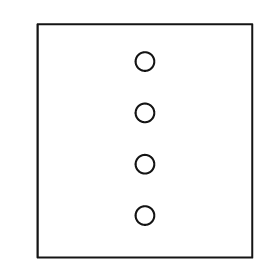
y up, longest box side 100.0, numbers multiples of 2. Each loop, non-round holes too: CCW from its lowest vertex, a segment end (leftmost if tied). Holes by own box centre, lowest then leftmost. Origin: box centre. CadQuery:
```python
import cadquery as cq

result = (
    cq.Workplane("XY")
    .moveTo(-46.0, -50.0)
    .lineTo(46.0, -50.0)
    .lineTo(46.0, 50.0)
    .lineTo(-46.0, 50.0)
    .close()
    .moveTo(0.0, -32.0)
    .circle(4.0)
    .moveTo(0.0, -10.0)
    .circle(4.0)
    .moveTo(0.0, 12.0)
    .circle(4.0)
    .moveTo(0.0, 34.0)
    .circle(4.0)
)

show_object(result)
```